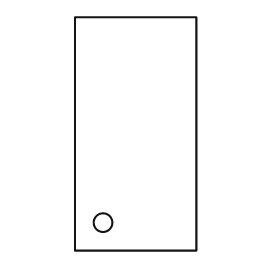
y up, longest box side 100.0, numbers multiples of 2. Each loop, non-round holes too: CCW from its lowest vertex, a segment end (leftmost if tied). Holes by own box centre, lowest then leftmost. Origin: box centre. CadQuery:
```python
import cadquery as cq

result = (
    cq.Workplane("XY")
    .moveTo(-26.0, -50.0)
    .lineTo(26.0, -50.0)
    .lineTo(26.0, 50.0)
    .lineTo(-26.0, 50.0)
    .close()
    .moveTo(-14.0, -38.0)
    .circle(4.0)
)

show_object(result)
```